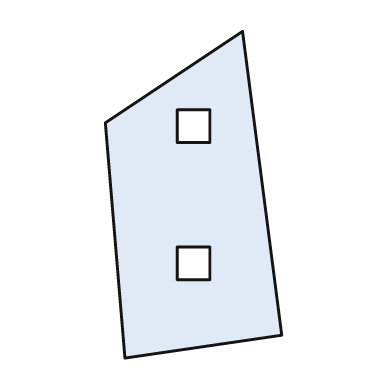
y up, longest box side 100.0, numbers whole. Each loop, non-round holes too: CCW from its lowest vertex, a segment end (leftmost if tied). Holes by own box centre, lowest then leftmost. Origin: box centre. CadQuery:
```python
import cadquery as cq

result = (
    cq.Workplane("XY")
    .moveTo(-21.0, -50.0)
    .lineTo(27.0, -43.0)
    .lineTo(15.0, 50.0)
    .lineTo(-27.0, 22.0)
    .close()
    .moveTo(-5.0, -26.0)
    .lineTo(5.0, -26.0)
    .lineTo(5.0, -16.0)
    .lineTo(-5.0, -16.0)
    .close()
    .moveTo(-5.0, 16.0)
    .lineTo(5.0, 16.0)
    .lineTo(5.0, 26.0)
    .lineTo(-5.0, 26.0)
    .close()
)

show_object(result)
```